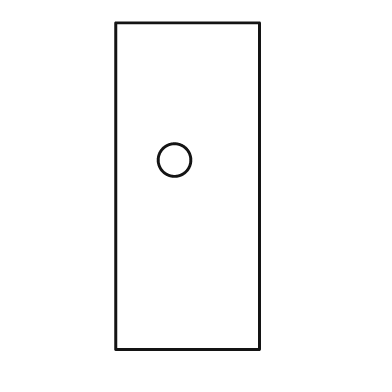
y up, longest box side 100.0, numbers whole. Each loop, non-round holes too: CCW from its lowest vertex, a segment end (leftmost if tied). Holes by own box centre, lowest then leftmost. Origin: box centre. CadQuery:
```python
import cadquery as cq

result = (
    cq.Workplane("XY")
    .moveTo(-22.0, -50.0)
    .lineTo(22.0, -50.0)
    .lineTo(22.0, 50.0)
    .lineTo(-22.0, 50.0)
    .close()
    .moveTo(-4.0, 8.0)
    .circle(5.0)
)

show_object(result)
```